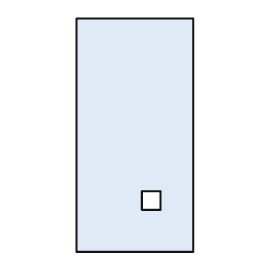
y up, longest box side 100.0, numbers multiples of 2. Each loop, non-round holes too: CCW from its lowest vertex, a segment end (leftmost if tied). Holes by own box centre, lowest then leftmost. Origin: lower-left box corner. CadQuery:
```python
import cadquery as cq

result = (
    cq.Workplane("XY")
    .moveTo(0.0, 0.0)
    .lineTo(50.0, 0.0)
    .lineTo(50.0, 100.0)
    .lineTo(0.0, 100.0)
    .close()
    .moveTo(28.0, 18.0)
    .lineTo(36.0, 18.0)
    .lineTo(36.0, 26.0)
    .lineTo(28.0, 26.0)
    .close()
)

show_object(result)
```